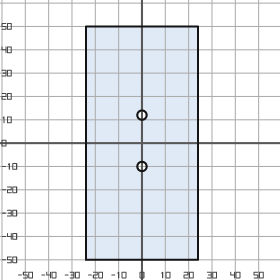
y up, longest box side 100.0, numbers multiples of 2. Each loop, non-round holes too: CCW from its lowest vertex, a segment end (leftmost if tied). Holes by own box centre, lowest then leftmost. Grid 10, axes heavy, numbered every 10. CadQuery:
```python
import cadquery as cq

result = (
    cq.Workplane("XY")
    .moveTo(-24.0, -50.0)
    .lineTo(24.0, -50.0)
    .lineTo(24.0, 50.0)
    .lineTo(-24.0, 50.0)
    .close()
    .moveTo(0.0, -10.0)
    .circle(2.0)
    .moveTo(0.0, 12.0)
    .circle(2.0)
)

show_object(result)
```